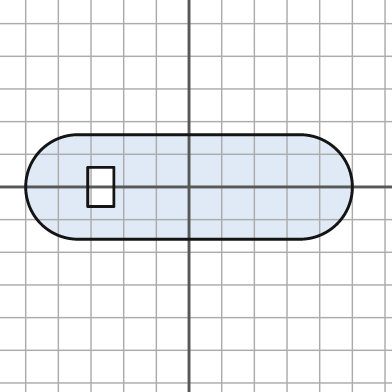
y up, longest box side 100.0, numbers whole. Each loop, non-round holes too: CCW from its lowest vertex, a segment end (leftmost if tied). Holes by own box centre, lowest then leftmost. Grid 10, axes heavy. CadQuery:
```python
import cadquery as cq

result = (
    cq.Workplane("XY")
    .moveTo(-34.0, -16.0)
    .lineTo(34.0, -16.0)
    .threePointArc((50.0, 0.0), (34.0, 16.0))
    .lineTo(-34.0, 16.0)
    .threePointArc((-50.0, 0.0), (-34.0, -16.0))
    .close()
    .moveTo(-31.0, -6.0)
    .lineTo(-23.0, -6.0)
    .lineTo(-23.0, 6.0)
    .lineTo(-31.0, 6.0)
    .close()
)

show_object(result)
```